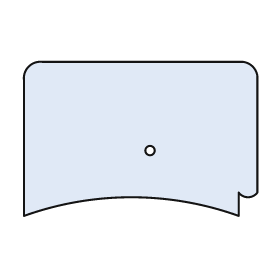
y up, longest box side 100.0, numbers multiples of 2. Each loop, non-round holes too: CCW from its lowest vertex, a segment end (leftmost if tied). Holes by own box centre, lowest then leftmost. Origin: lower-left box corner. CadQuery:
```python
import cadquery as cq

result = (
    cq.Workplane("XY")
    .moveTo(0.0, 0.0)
    .threePointArc((46.0, 8.0), (92.0, 0.0))
    .lineTo(92.0, 10.0)
    .threePointArc((96.0, 8.0), (100.0, 10.0))
    .lineTo(100.0, 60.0)
    .threePointArc((98.0, 64.0), (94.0, 66.0))
    .lineTo(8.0, 66.0)
    .threePointArc((2.0, 64.0), (0.0, 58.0))
    .close()
    .moveTo(54.0, 28.0)
    .circle(2.0)
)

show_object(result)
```